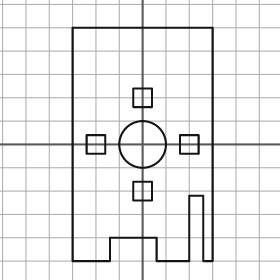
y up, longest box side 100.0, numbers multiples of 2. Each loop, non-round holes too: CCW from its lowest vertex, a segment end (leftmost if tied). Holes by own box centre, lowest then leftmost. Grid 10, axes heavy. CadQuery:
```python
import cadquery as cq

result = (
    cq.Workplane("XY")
    .moveTo(-30.0, -50.0)
    .lineTo(-14.0, -50.0)
    .lineTo(-14.0, -40.0)
    .lineTo(6.0, -40.0)
    .lineTo(6.0, -50.0)
    .lineTo(20.0, -50.0)
    .lineTo(20.0, -22.0)
    .lineTo(26.0, -22.0)
    .lineTo(26.0, -50.0)
    .lineTo(30.0, -50.0)
    .lineTo(30.0, 50.0)
    .lineTo(-30.0, 50.0)
    .close()
    .moveTo(-4.0, -24.0)
    .lineTo(4.0, -24.0)
    .lineTo(4.0, -16.0)
    .lineTo(-4.0, -16.0)
    .close()
    .moveTo(-24.0, -4.0)
    .lineTo(-16.0, -4.0)
    .lineTo(-16.0, 4.0)
    .lineTo(-24.0, 4.0)
    .close()
    .moveTo(0.0, 0.0)
    .circle(10.0)
    .moveTo(16.0, -4.0)
    .lineTo(24.0, -4.0)
    .lineTo(24.0, 4.0)
    .lineTo(16.0, 4.0)
    .close()
    .moveTo(-4.0, 16.0)
    .lineTo(4.0, 16.0)
    .lineTo(4.0, 24.0)
    .lineTo(-4.0, 24.0)
    .close()
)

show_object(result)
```